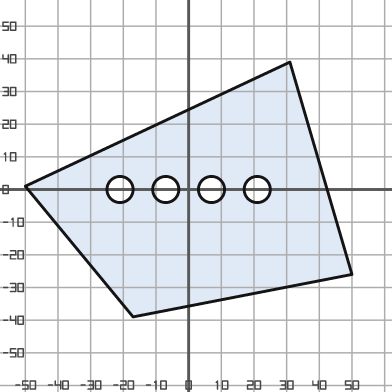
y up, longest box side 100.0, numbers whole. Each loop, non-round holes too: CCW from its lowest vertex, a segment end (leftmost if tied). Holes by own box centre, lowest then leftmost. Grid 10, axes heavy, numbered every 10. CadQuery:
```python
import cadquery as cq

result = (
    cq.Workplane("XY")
    .moveTo(-17.0, -39.0)
    .lineTo(50.0, -26.0)
    .lineTo(31.0, 39.0)
    .lineTo(-50.0, 1.0)
    .close()
    .moveTo(-21.0, 0.0)
    .circle(4.0)
    .moveTo(-7.0, 0.0)
    .circle(4.0)
    .moveTo(7.0, 0.0)
    .circle(4.0)
    .moveTo(21.0, 0.0)
    .circle(4.0)
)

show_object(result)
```